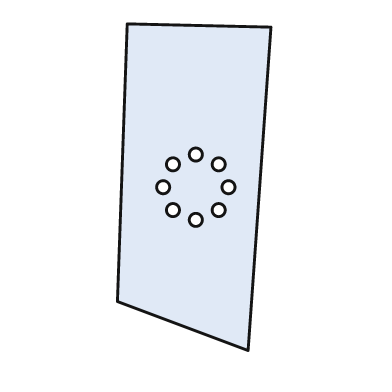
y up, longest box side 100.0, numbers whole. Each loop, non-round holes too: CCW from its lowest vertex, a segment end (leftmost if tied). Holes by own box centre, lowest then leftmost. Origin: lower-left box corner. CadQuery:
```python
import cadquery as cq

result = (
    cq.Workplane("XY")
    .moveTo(40.0, 0.0)
    .lineTo(47.0, 99.0)
    .lineTo(3.0, 100.0)
    .lineTo(0.0, 15.0)
    .close()
    .moveTo(24.0, 40.0)
    .circle(2.0)
    .moveTo(17.0, 43.0)
    .circle(2.0)
    .moveTo(31.0, 43.0)
    .circle(2.0)
    .moveTo(14.0, 50.0)
    .circle(2.0)
    .moveTo(34.0, 50.0)
    .circle(2.0)
    .moveTo(17.0, 57.0)
    .circle(2.0)
    .moveTo(31.0, 57.0)
    .circle(2.0)
    .moveTo(24.0, 60.0)
    .circle(2.0)
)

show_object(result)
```